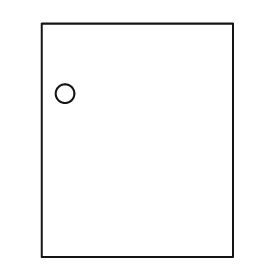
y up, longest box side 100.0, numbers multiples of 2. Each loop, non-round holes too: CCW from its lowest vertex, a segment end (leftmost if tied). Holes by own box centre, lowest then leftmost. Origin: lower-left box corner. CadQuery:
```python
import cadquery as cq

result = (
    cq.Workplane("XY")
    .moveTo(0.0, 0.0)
    .lineTo(82.0, 0.0)
    .lineTo(82.0, 100.0)
    .lineTo(0.0, 100.0)
    .close()
    .moveTo(10.0, 70.0)
    .circle(4.0)
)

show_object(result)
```